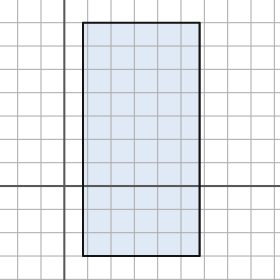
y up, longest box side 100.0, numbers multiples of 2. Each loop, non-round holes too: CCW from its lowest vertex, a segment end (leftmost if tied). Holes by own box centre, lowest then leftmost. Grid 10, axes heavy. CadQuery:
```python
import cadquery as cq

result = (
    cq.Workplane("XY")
    .moveTo(8.0, -30.0)
    .lineTo(58.0, -30.0)
    .lineTo(58.0, 70.0)
    .lineTo(8.0, 70.0)
    .close()
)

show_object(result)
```